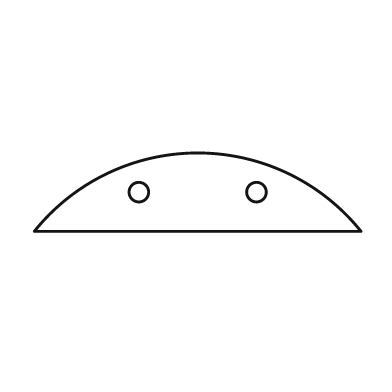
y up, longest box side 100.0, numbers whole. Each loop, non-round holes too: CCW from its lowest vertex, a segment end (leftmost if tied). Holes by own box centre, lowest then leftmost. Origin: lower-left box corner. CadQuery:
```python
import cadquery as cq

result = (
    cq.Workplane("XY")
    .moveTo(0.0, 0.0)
    .lineTo(100.0, 0.0)
    .threePointArc((50.0, 24.0), (0.0, 0.0))
    .close()
    .moveTo(32.0, 12.0)
    .circle(3.0)
    .moveTo(68.0, 12.0)
    .circle(3.0)
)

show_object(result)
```